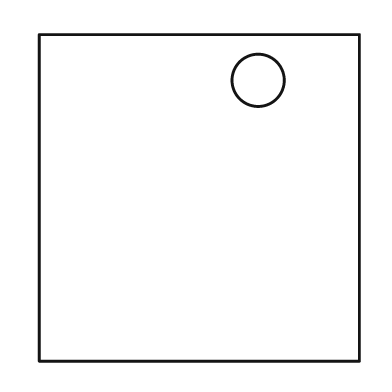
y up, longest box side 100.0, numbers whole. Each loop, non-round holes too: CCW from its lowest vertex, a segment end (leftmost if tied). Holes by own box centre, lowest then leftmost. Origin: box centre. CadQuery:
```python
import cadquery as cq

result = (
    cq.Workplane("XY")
    .moveTo(-49.0, -50.0)
    .lineTo(49.0, -50.0)
    .lineTo(49.0, 50.0)
    .lineTo(-49.0, 50.0)
    .close()
    .moveTo(18.0, 36.0)
    .circle(8.0)
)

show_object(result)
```